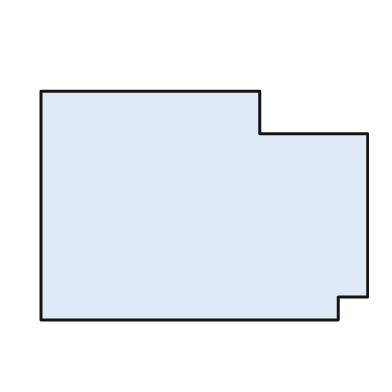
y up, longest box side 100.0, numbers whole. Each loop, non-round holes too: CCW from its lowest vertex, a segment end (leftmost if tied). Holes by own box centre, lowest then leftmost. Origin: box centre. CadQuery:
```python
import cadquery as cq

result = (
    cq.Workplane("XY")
    .moveTo(-50.0, -35.0)
    .lineTo(41.0, -35.0)
    .lineTo(41.0, -28.0)
    .lineTo(50.0, -28.0)
    .lineTo(50.0, 22.0)
    .lineTo(17.0, 22.0)
    .lineTo(17.0, 35.0)
    .lineTo(-50.0, 35.0)
    .close()
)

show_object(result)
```